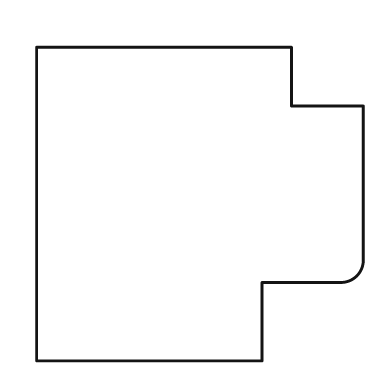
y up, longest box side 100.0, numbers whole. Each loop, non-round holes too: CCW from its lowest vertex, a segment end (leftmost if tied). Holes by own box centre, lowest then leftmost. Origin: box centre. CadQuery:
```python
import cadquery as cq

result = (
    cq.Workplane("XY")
    .moveTo(-50.0, -48.0)
    .lineTo(19.0, -48.0)
    .lineTo(19.0, -24.0)
    .lineTo(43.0, -24.0)
    .threePointArc((48.0, -22.0), (50.0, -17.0))
    .lineTo(50.0, 30.0)
    .lineTo(28.0, 30.0)
    .lineTo(28.0, 48.0)
    .lineTo(-50.0, 48.0)
    .close()
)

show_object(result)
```